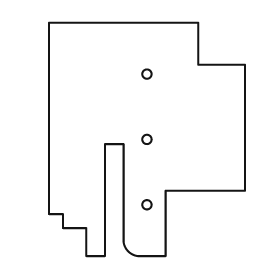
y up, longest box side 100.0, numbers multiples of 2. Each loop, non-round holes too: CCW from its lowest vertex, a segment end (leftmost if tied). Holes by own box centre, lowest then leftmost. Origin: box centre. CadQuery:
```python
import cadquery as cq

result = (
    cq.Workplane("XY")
    .moveTo(-26.0, -50.0)
    .lineTo(-18.0, -50.0)
    .lineTo(-18.0, -2.0)
    .lineTo(-10.0, -2.0)
    .lineTo(-10.0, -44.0)
    .threePointArc((-8.0, -48.0), (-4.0, -50.0))
    .lineTo(8.0, -50.0)
    .lineTo(8.0, -22.0)
    .lineTo(42.0, -22.0)
    .lineTo(42.0, 32.0)
    .lineTo(22.0, 32.0)
    .lineTo(22.0, 50.0)
    .lineTo(-42.0, 50.0)
    .lineTo(-42.0, -32.0)
    .lineTo(-36.0, -32.0)
    .lineTo(-36.0, -38.0)
    .lineTo(-26.0, -38.0)
    .close()
    .moveTo(0.0, -28.0)
    .circle(2.0)
    .moveTo(0.0, 0.0)
    .circle(2.0)
    .moveTo(0.0, 28.0)
    .circle(2.0)
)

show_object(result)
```